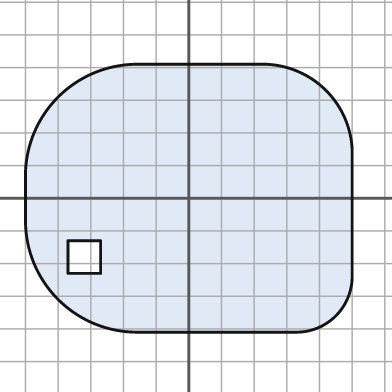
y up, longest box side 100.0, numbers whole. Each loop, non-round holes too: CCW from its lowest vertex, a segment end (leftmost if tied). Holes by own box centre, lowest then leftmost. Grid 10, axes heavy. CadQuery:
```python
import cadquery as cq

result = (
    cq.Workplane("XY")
    .moveTo(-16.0, -41.0)
    .lineTo(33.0, -41.0)
    .threePointArc((45.0, -36.0), (50.0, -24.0))
    .lineTo(50.0, 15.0)
    .threePointArc((42.0, 33.0), (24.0, 41.0))
    .lineTo(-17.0, 41.0)
    .threePointArc((-40.0, 31.0), (-50.0, 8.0))
    .lineTo(-50.0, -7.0)
    .threePointArc((-40.0, -31.0), (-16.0, -41.0))
    .close()
    .moveTo(-37.0, -23.0)
    .lineTo(-27.0, -23.0)
    .lineTo(-27.0, -13.0)
    .lineTo(-37.0, -13.0)
    .close()
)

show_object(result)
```